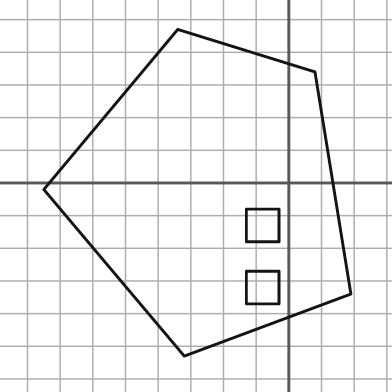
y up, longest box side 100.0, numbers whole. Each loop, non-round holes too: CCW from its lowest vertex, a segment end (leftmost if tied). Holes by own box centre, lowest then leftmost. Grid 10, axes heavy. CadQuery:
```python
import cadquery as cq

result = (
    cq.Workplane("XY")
    .moveTo(-32.0, -53.0)
    .lineTo(19.0, -34.0)
    .lineTo(8.0, 34.0)
    .lineTo(-34.0, 47.0)
    .lineTo(-75.0, -2.0)
    .close()
    .moveTo(-13.0, -37.0)
    .lineTo(-3.0, -37.0)
    .lineTo(-3.0, -27.0)
    .lineTo(-13.0, -27.0)
    .close()
    .moveTo(-13.0, -18.0)
    .lineTo(-3.0, -18.0)
    .lineTo(-3.0, -8.0)
    .lineTo(-13.0, -8.0)
    .close()
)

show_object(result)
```